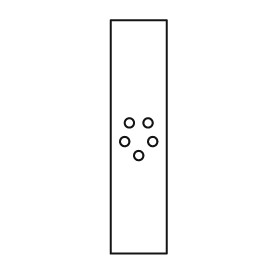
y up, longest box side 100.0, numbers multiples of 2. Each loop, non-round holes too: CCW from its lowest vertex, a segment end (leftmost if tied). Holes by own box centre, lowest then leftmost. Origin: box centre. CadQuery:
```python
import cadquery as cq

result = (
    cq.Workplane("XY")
    .moveTo(-12.0, -50.0)
    .lineTo(12.0, -50.0)
    .lineTo(12.0, 50.0)
    .lineTo(-12.0, 50.0)
    .close()
    .moveTo(0.0, -8.0)
    .circle(2.0)
    .moveTo(-6.0, -2.0)
    .circle(2.0)
    .moveTo(6.0, -2.0)
    .circle(2.0)
    .moveTo(-4.0, 6.0)
    .circle(2.0)
    .moveTo(4.0, 6.0)
    .circle(2.0)
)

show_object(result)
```